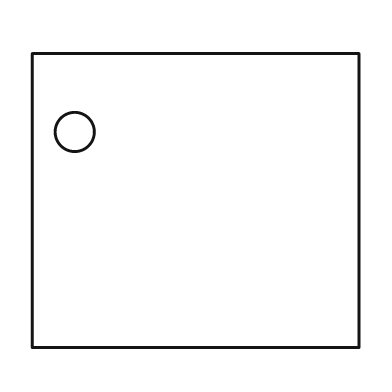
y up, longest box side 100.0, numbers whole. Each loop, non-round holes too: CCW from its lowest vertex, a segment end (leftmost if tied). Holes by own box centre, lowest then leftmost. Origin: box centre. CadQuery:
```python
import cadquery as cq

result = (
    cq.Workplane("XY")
    .moveTo(-50.0, -45.0)
    .lineTo(50.0, -45.0)
    .lineTo(50.0, 45.0)
    .lineTo(-50.0, 45.0)
    .close()
    .moveTo(-37.0, 21.0)
    .circle(6.0)
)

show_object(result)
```